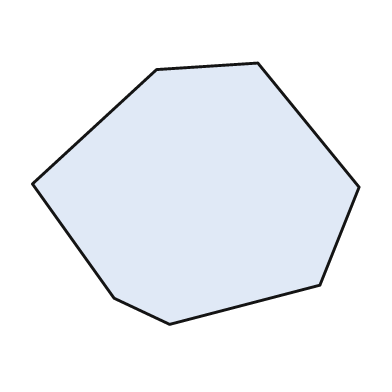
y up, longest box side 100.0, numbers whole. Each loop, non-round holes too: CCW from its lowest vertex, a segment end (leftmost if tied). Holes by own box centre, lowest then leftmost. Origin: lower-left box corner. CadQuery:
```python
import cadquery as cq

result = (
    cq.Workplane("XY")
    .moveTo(42.0, 0.0)
    .lineTo(88.0, 12.0)
    .lineTo(100.0, 42.0)
    .lineTo(69.0, 80.0)
    .lineTo(38.0, 78.0)
    .lineTo(0.0, 43.0)
    .lineTo(25.0, 8.0)
    .close()
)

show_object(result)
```